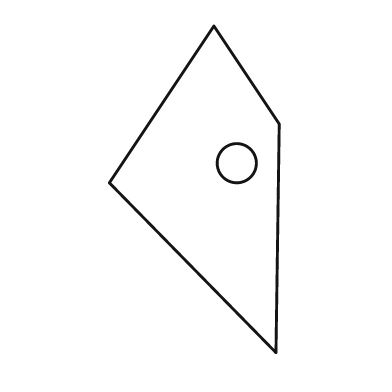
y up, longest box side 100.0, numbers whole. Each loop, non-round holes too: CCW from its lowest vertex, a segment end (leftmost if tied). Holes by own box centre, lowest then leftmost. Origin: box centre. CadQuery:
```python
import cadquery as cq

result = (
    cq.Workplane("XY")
    .moveTo(25.0, -50.0)
    .lineTo(26.0, 20.0)
    .lineTo(6.0, 50.0)
    .lineTo(-26.0, 2.0)
    .close()
    .moveTo(13.0, 8.0)
    .circle(6.0)
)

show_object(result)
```